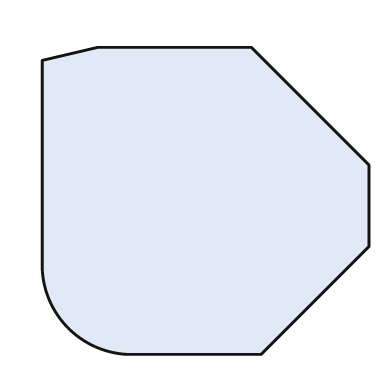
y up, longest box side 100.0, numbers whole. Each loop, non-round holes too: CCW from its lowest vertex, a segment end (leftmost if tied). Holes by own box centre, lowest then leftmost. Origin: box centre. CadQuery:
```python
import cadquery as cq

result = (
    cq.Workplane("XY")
    .moveTo(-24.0, -47.0)
    .lineTo(17.0, -47.0)
    .lineTo(50.0, -14.0)
    .lineTo(50.0, 11.0)
    .lineTo(14.0, 47.0)
    .lineTo(-33.0, 47.0)
    .lineTo(-50.0, 43.0)
    .lineTo(-50.0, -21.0)
    .threePointArc((-42.0, -39.0), (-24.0, -47.0))
    .close()
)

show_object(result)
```